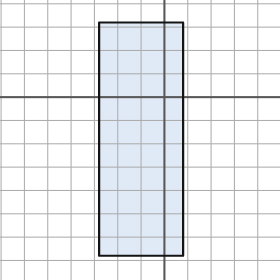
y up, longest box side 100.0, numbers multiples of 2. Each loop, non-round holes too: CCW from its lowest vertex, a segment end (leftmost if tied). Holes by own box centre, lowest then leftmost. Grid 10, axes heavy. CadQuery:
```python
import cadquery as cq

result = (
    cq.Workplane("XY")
    .moveTo(-28.0, -68.0)
    .lineTo(8.0, -68.0)
    .lineTo(8.0, 32.0)
    .lineTo(-28.0, 32.0)
    .close()
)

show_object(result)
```